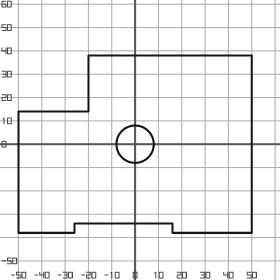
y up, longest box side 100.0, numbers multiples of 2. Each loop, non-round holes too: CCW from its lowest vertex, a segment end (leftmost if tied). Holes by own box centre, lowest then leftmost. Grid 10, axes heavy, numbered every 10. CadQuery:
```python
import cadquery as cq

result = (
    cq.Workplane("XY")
    .moveTo(-50.0, -38.0)
    .lineTo(-26.0, -38.0)
    .lineTo(-26.0, -34.0)
    .lineTo(16.0, -34.0)
    .lineTo(16.0, -38.0)
    .lineTo(50.0, -38.0)
    .lineTo(50.0, 38.0)
    .lineTo(-20.0, 38.0)
    .lineTo(-20.0, 14.0)
    .lineTo(-50.0, 14.0)
    .close()
    .moveTo(0.0, 0.0)
    .circle(8.0)
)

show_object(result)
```